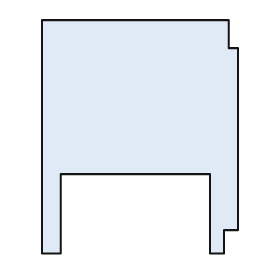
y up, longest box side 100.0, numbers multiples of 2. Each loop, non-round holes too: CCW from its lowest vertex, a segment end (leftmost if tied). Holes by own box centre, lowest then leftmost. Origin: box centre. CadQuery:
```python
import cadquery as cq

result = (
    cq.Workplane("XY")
    .moveTo(-42.0, -50.0)
    .lineTo(-34.0, -50.0)
    .lineTo(-34.0, -16.0)
    .lineTo(30.0, -16.0)
    .lineTo(30.0, -50.0)
    .lineTo(36.0, -50.0)
    .lineTo(36.0, -40.0)
    .lineTo(42.0, -40.0)
    .lineTo(42.0, 38.0)
    .lineTo(38.0, 38.0)
    .lineTo(38.0, 50.0)
    .lineTo(-42.0, 50.0)
    .close()
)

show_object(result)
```